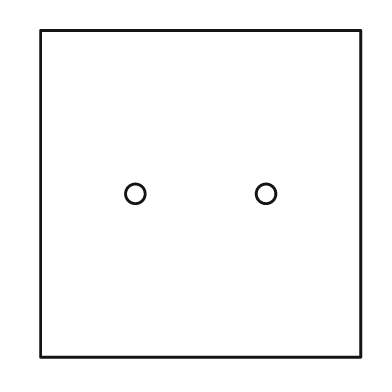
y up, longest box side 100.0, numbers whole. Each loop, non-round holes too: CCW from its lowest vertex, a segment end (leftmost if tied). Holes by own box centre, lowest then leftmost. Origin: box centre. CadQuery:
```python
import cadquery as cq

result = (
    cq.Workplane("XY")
    .moveTo(-49.0, -50.0)
    .lineTo(49.0, -50.0)
    .lineTo(49.0, 50.0)
    .lineTo(-49.0, 50.0)
    .close()
    .moveTo(-20.0, 0.0)
    .circle(3.0)
    .moveTo(20.0, 0.0)
    .circle(3.0)
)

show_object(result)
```